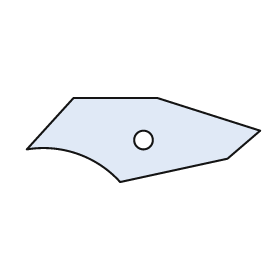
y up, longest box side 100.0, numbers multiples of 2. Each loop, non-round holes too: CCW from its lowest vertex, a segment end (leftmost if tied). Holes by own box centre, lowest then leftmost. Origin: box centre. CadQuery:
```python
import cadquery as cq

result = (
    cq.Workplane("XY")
    .moveTo(-10.0, -18.0)
    .lineTo(36.0, -8.0)
    .lineTo(50.0, 4.0)
    .lineTo(6.0, 18.0)
    .lineTo(-30.0, 18.0)
    .lineTo(-50.0, -4.0)
    .threePointArc((-28.0, -6.0), (-10.0, -18.0))
    .close()
    .moveTo(0.0, 0.0)
    .circle(4.0)
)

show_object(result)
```